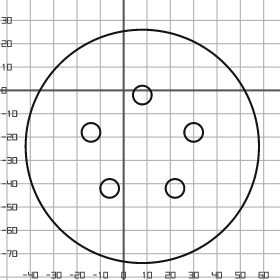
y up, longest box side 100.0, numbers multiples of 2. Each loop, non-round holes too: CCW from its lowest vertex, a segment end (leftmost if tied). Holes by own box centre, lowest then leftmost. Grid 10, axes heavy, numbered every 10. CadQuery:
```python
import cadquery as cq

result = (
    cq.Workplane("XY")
    .moveTo(8.0, -24.0)
    .circle(50.0)
    .moveTo(-6.0, -42.0)
    .circle(4.0)
    .moveTo(22.0, -42.0)
    .circle(4.0)
    .moveTo(-14.0, -18.0)
    .circle(4.0)
    .moveTo(30.0, -18.0)
    .circle(4.0)
    .moveTo(8.0, -2.0)
    .circle(4.0)
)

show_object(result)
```